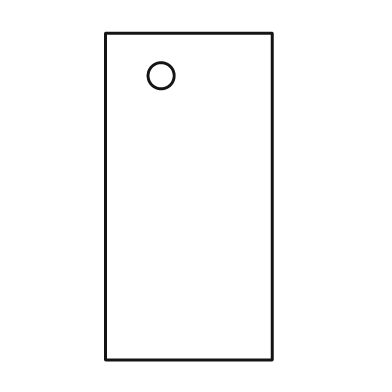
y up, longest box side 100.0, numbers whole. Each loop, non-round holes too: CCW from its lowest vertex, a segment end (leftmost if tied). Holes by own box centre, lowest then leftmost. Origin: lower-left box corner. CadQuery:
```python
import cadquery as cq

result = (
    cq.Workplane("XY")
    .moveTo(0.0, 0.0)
    .lineTo(51.0, 0.0)
    .lineTo(51.0, 100.0)
    .lineTo(0.0, 100.0)
    .close()
    .moveTo(17.0, 87.0)
    .circle(4.0)
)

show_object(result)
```